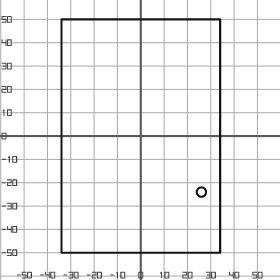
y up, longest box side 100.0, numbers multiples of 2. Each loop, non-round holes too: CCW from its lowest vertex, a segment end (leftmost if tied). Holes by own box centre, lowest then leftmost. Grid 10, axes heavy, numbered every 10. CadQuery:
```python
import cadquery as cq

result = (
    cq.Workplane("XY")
    .moveTo(-34.0, -50.0)
    .lineTo(34.0, -50.0)
    .lineTo(34.0, 50.0)
    .lineTo(-34.0, 50.0)
    .close()
    .moveTo(26.0, -24.0)
    .circle(2.0)
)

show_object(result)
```